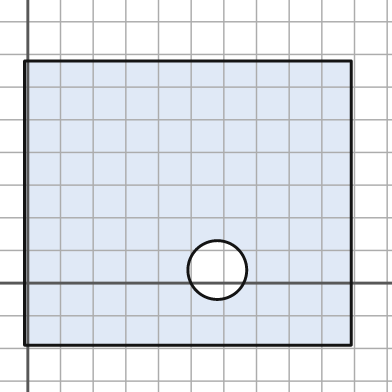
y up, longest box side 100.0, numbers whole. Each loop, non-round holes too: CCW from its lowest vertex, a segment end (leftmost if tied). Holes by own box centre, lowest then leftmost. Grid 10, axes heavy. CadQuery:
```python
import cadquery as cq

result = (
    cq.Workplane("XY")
    .moveTo(-1.0, -19.0)
    .lineTo(99.0, -19.0)
    .lineTo(99.0, 68.0)
    .lineTo(-1.0, 68.0)
    .close()
    .moveTo(58.0, 4.0)
    .circle(9.0)
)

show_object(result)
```